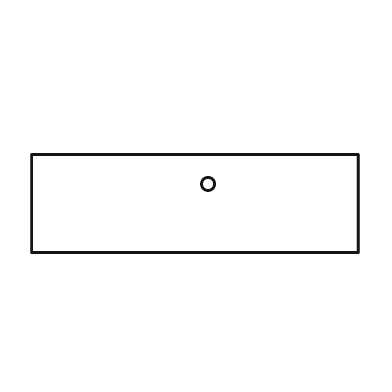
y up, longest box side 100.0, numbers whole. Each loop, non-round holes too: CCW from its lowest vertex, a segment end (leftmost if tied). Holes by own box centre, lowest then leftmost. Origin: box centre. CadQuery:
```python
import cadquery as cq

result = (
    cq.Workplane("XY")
    .moveTo(-50.0, -15.0)
    .lineTo(50.0, -15.0)
    .lineTo(50.0, 15.0)
    .lineTo(-50.0, 15.0)
    .close()
    .moveTo(4.0, 6.0)
    .circle(2.0)
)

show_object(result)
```